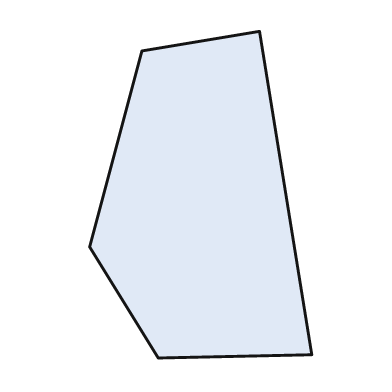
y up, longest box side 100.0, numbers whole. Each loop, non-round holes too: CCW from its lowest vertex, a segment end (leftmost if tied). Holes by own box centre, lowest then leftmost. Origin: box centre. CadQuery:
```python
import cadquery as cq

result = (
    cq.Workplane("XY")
    .moveTo(-13.0, -50.0)
    .lineTo(34.0, -49.0)
    .lineTo(18.0, 50.0)
    .lineTo(-18.0, 44.0)
    .lineTo(-34.0, -16.0)
    .close()
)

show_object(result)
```